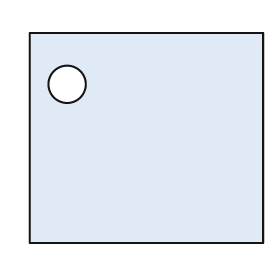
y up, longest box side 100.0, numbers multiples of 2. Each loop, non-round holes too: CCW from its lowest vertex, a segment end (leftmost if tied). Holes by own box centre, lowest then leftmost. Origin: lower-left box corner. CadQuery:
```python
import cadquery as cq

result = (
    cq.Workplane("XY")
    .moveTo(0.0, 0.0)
    .lineTo(100.0, 0.0)
    .lineTo(100.0, 90.0)
    .lineTo(0.0, 90.0)
    .close()
    .moveTo(16.0, 68.0)
    .circle(8.0)
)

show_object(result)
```